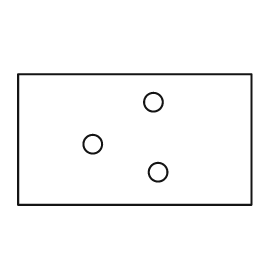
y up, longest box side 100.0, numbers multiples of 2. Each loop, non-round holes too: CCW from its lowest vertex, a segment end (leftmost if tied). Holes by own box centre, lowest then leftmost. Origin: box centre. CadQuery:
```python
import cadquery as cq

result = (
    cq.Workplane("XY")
    .moveTo(-50.0, -28.0)
    .lineTo(50.0, -28.0)
    .lineTo(50.0, 28.0)
    .lineTo(-50.0, 28.0)
    .close()
    .moveTo(10.0, -14.0)
    .circle(4.0)
    .moveTo(-18.0, -2.0)
    .circle(4.0)
    .moveTo(8.0, 16.0)
    .circle(4.0)
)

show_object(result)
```